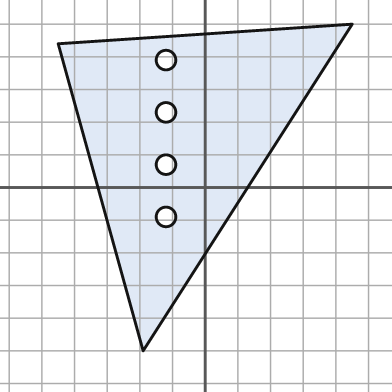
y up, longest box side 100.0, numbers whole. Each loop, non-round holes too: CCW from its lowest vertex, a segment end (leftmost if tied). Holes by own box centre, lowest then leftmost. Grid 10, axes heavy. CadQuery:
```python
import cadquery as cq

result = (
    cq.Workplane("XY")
    .moveTo(-19.0, -50.0)
    .lineTo(45.0, 50.0)
    .lineTo(-45.0, 44.0)
    .close()
    .moveTo(-12.0, -9.0)
    .circle(3.0)
    .moveTo(-12.0, 7.0)
    .circle(3.0)
    .moveTo(-12.0, 23.0)
    .circle(3.0)
    .moveTo(-12.0, 39.0)
    .circle(3.0)
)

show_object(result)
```